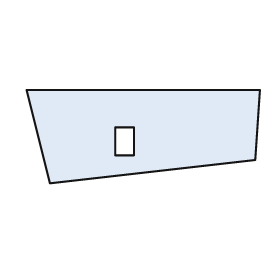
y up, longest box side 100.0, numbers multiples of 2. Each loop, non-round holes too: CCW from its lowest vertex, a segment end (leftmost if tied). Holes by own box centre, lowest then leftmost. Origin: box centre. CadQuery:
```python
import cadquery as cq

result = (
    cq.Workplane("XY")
    .moveTo(-40.0, -20.0)
    .lineTo(48.0, -10.0)
    .lineTo(50.0, 20.0)
    .lineTo(-50.0, 20.0)
    .close()
    .moveTo(-12.0, -8.0)
    .lineTo(-4.0, -8.0)
    .lineTo(-4.0, 4.0)
    .lineTo(-12.0, 4.0)
    .close()
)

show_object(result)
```